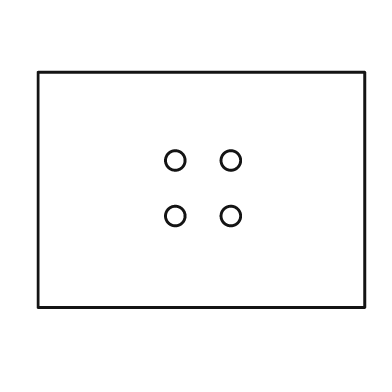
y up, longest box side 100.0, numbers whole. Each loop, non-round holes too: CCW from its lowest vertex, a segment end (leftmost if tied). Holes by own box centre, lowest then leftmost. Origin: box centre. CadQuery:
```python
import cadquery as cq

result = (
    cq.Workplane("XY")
    .moveTo(-50.0, -36.0)
    .lineTo(50.0, -36.0)
    .lineTo(50.0, 36.0)
    .lineTo(-50.0, 36.0)
    .close()
    .moveTo(-8.0, -8.0)
    .circle(3.0)
    .moveTo(9.0, -8.0)
    .circle(3.0)
    .moveTo(-8.0, 9.0)
    .circle(3.0)
    .moveTo(9.0, 9.0)
    .circle(3.0)
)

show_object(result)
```